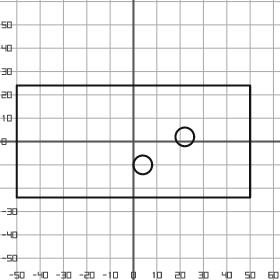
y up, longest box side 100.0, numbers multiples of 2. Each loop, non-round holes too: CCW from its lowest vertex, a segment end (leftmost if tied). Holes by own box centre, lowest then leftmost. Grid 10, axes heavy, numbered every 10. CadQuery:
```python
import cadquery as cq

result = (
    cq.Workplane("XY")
    .moveTo(-50.0, -24.0)
    .lineTo(50.0, -24.0)
    .lineTo(50.0, 24.0)
    .lineTo(-50.0, 24.0)
    .close()
    .moveTo(4.0, -10.0)
    .circle(4.0)
    .moveTo(22.0, 2.0)
    .circle(4.0)
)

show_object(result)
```